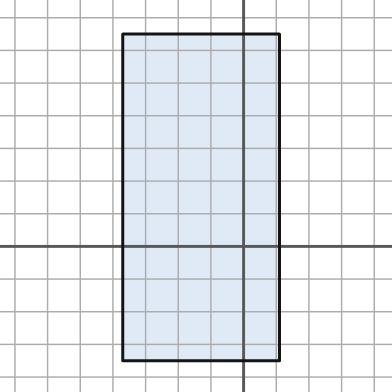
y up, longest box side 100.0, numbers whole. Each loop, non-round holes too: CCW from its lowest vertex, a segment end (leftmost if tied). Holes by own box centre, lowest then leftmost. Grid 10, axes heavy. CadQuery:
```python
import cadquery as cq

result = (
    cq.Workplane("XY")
    .moveTo(-37.0, -35.0)
    .lineTo(11.0, -35.0)
    .lineTo(11.0, 65.0)
    .lineTo(-37.0, 65.0)
    .close()
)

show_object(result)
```